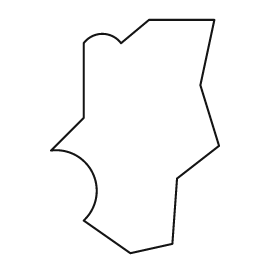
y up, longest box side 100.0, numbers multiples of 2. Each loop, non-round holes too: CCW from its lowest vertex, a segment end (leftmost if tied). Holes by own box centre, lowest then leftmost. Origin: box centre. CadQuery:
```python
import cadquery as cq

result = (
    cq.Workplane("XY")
    .moveTo(-2.0, -50.0)
    .lineTo(16.0, -46.0)
    .lineTo(18.0, -18.0)
    .lineTo(36.0, -4.0)
    .lineTo(28.0, 22.0)
    .lineTo(34.0, 50.0)
    .lineTo(6.0, 50.0)
    .lineTo(-6.0, 40.0)
    .threePointArc((-14.0, 44.0), (-22.0, 40.0))
    .lineTo(-22.0, 8.0)
    .lineTo(-36.0, -6.0)
    .threePointArc((-18.0, -16.0), (-22.0, -36.0))
    .close()
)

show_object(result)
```